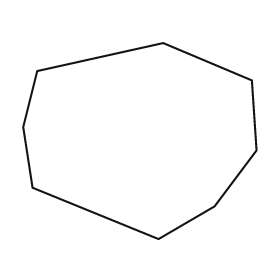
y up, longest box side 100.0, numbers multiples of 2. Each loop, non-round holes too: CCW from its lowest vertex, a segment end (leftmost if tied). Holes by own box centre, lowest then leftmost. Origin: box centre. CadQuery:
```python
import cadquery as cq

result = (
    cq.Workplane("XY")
    .moveTo(8.0, -42.0)
    .lineTo(32.0, -28.0)
    .lineTo(50.0, -4.0)
    .lineTo(48.0, 26.0)
    .lineTo(10.0, 42.0)
    .lineTo(-44.0, 30.0)
    .lineTo(-50.0, 6.0)
    .lineTo(-46.0, -20.0)
    .close()
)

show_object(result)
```